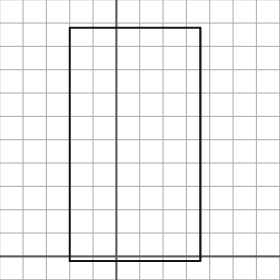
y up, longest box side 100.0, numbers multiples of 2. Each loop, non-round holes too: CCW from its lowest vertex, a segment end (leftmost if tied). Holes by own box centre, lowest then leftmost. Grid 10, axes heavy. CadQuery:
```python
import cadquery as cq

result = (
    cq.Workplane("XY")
    .moveTo(-20.0, -2.0)
    .lineTo(36.0, -2.0)
    .lineTo(36.0, 98.0)
    .lineTo(-20.0, 98.0)
    .close()
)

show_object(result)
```